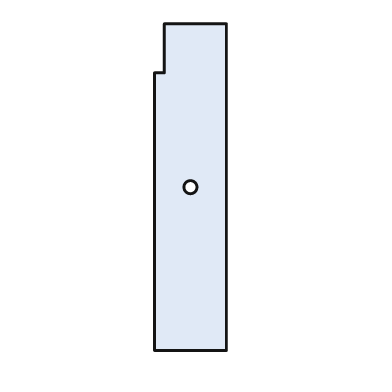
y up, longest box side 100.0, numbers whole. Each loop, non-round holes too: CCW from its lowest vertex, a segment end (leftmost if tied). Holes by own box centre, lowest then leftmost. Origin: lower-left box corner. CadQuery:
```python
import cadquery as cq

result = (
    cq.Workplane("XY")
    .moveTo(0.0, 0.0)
    .lineTo(22.0, 0.0)
    .lineTo(22.0, 100.0)
    .lineTo(3.0, 100.0)
    .lineTo(3.0, 85.0)
    .lineTo(0.0, 85.0)
    .close()
    .moveTo(11.0, 50.0)
    .circle(2.0)
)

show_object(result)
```